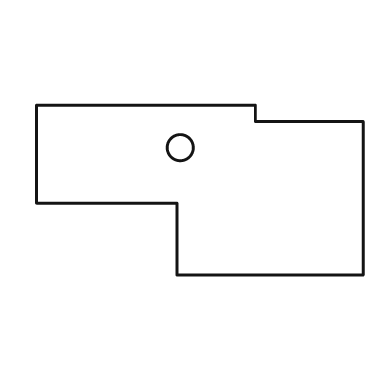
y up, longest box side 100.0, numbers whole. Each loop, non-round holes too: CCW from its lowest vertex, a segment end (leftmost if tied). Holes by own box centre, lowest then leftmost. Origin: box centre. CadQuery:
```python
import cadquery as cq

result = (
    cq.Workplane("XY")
    .moveTo(-7.0, -26.0)
    .lineTo(50.0, -26.0)
    .lineTo(50.0, 21.0)
    .lineTo(17.0, 21.0)
    .lineTo(17.0, 26.0)
    .lineTo(-50.0, 26.0)
    .lineTo(-50.0, -4.0)
    .lineTo(-7.0, -4.0)
    .close()
    .moveTo(-6.0, 13.0)
    .circle(4.0)
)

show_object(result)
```